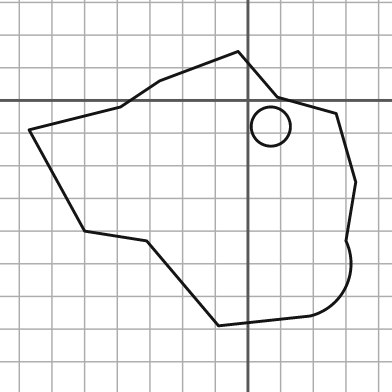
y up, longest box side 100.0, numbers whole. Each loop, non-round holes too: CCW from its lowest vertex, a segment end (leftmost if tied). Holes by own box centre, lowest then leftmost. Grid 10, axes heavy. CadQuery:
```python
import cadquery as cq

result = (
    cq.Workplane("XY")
    .moveTo(-9.0, -69.0)
    .lineTo(19.0, -66.0)
    .threePointArc((30.0, -57.0), (30.0, -43.0))
    .lineTo(33.0, -25.0)
    .lineTo(27.0, -4.0)
    .lineTo(9.0, 1.0)
    .lineTo(-3.0, 15.0)
    .lineTo(-27.0, 6.0)
    .lineTo(-39.0, -2.0)
    .lineTo(-67.0, -9.0)
    .lineTo(-50.0, -40.0)
    .lineTo(-31.0, -43.0)
    .close()
    .moveTo(7.0, -8.0)
    .circle(6.0)
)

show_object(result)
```